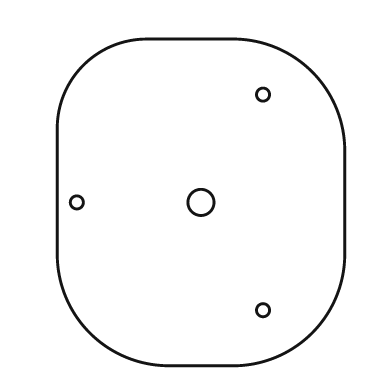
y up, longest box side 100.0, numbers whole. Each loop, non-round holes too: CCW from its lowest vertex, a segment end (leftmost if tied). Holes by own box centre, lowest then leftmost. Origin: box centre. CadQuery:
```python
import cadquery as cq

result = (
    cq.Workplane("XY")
    .moveTo(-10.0, -50.0)
    .lineTo(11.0, -50.0)
    .threePointArc((34.0, -40.0), (44.0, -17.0))
    .lineTo(44.0, 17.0)
    .threePointArc((34.0, 40.0), (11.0, 50.0))
    .lineTo(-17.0, 50.0)
    .threePointArc((-36.0, 42.0), (-44.0, 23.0))
    .lineTo(-44.0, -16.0)
    .threePointArc((-34.0, -40.0), (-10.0, -50.0))
    .close()
    .moveTo(19.0, -33.0)
    .circle(2.0)
    .moveTo(-38.0, 0.0)
    .circle(2.0)
    .moveTo(0.0, 0.0)
    .circle(4.0)
    .moveTo(19.0, 33.0)
    .circle(2.0)
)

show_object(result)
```